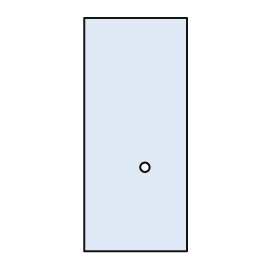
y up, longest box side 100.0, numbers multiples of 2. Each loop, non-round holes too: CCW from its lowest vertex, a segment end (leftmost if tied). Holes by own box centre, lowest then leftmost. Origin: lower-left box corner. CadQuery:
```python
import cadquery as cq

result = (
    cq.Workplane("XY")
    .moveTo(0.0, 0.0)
    .lineTo(44.0, 0.0)
    .lineTo(44.0, 100.0)
    .lineTo(0.0, 100.0)
    .close()
    .moveTo(26.0, 36.0)
    .circle(2.0)
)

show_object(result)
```